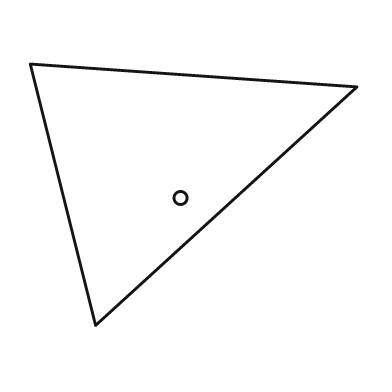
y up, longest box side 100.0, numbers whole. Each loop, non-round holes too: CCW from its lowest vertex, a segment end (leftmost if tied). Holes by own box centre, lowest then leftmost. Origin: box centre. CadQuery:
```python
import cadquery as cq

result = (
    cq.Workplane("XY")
    .moveTo(-30.0, -40.0)
    .lineTo(50.0, 33.0)
    .lineTo(-50.0, 40.0)
    .close()
    .moveTo(-4.0, -1.0)
    .circle(2.0)
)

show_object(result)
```